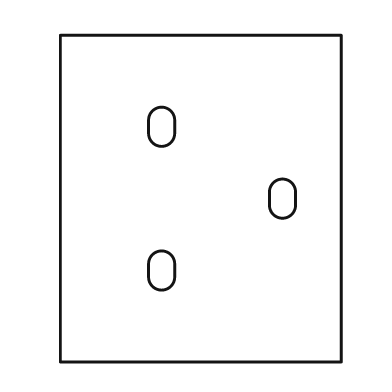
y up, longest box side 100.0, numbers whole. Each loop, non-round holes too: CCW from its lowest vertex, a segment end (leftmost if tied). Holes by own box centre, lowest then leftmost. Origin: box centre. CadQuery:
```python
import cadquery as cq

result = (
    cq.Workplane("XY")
    .moveTo(-43.0, -50.0)
    .lineTo(43.0, -50.0)
    .lineTo(43.0, 50.0)
    .lineTo(-43.0, 50.0)
    .close()
    .moveTo(-16.0, -24.0)
    .threePointArc((-12.0, -28.0), (-8.0, -24.0))
    .lineTo(-8.0, -20.0)
    .threePointArc((-12.0, -16.0), (-16.0, -20.0))
    .close()
    .moveTo(21.0, -2.0)
    .threePointArc((25.0, -6.0), (29.0, -2.0))
    .lineTo(29.0, 2.0)
    .threePointArc((25.0, 6.0), (21.0, 2.0))
    .close()
    .moveTo(-16.0, 20.0)
    .threePointArc((-12.0, 16.0), (-8.0, 20.0))
    .lineTo(-8.0, 24.0)
    .threePointArc((-12.0, 28.0), (-16.0, 24.0))
    .close()
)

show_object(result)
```